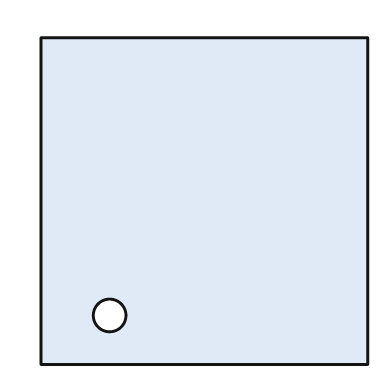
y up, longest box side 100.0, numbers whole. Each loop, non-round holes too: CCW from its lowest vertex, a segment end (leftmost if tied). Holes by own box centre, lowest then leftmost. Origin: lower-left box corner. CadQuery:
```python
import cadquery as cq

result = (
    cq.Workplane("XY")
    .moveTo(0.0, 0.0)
    .lineTo(100.0, 0.0)
    .lineTo(100.0, 100.0)
    .lineTo(0.0, 100.0)
    .close()
    .moveTo(21.0, 15.0)
    .circle(5.0)
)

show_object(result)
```